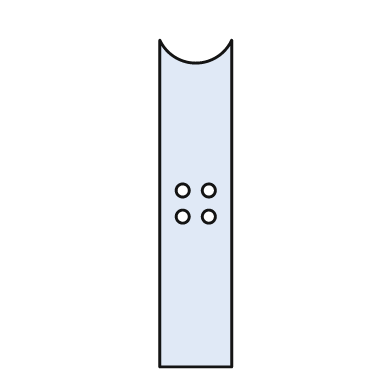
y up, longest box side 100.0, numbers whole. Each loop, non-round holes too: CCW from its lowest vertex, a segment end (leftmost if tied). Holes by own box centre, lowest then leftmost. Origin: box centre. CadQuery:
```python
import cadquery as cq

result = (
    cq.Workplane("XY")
    .moveTo(-11.0, -50.0)
    .lineTo(11.0, -50.0)
    .lineTo(11.0, 50.0)
    .threePointArc((0.0, 43.0), (-11.0, 50.0))
    .close()
    .moveTo(-4.0, -4.0)
    .circle(2.0)
    .moveTo(4.0, -4.0)
    .circle(2.0)
    .moveTo(-4.0, 4.0)
    .circle(2.0)
    .moveTo(4.0, 4.0)
    .circle(2.0)
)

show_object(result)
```